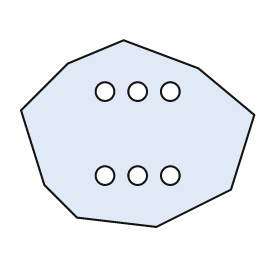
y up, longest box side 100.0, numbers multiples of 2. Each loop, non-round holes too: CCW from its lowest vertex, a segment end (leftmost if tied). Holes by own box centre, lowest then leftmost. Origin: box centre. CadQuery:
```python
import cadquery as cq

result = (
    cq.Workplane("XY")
    .moveTo(8.0, -40.0)
    .lineTo(40.0, -24.0)
    .lineTo(50.0, 8.0)
    .lineTo(26.0, 28.0)
    .lineTo(-6.0, 40.0)
    .lineTo(-30.0, 30.0)
    .lineTo(-50.0, 10.0)
    .lineTo(-40.0, -22.0)
    .lineTo(-26.0, -36.0)
    .close()
    .moveTo(-14.0, -18.0)
    .circle(4.0)
    .moveTo(0.0, -18.0)
    .circle(4.0)
    .moveTo(14.0, -18.0)
    .circle(4.0)
    .moveTo(-14.0, 18.0)
    .circle(4.0)
    .moveTo(0.0, 18.0)
    .circle(4.0)
    .moveTo(14.0, 18.0)
    .circle(4.0)
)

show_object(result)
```